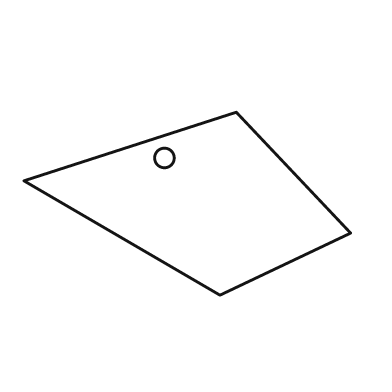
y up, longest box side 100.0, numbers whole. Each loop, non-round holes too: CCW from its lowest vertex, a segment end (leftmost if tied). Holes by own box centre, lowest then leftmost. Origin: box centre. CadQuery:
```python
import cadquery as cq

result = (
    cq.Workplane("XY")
    .moveTo(10.0, -28.0)
    .lineTo(50.0, -9.0)
    .lineTo(15.0, 28.0)
    .lineTo(-50.0, 7.0)
    .close()
    .moveTo(-7.0, 14.0)
    .circle(3.0)
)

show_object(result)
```